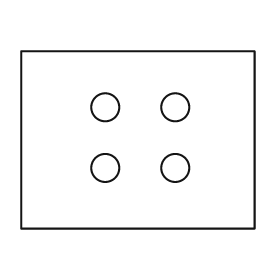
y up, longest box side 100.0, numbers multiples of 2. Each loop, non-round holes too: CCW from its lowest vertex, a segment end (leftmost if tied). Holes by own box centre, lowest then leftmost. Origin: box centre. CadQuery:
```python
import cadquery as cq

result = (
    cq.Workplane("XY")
    .moveTo(-50.0, -38.0)
    .lineTo(50.0, -38.0)
    .lineTo(50.0, 38.0)
    .lineTo(-50.0, 38.0)
    .close()
    .moveTo(-14.0, -12.0)
    .circle(6.0)
    .moveTo(16.0, -12.0)
    .circle(6.0)
    .moveTo(-14.0, 14.0)
    .circle(6.0)
    .moveTo(16.0, 14.0)
    .circle(6.0)
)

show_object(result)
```